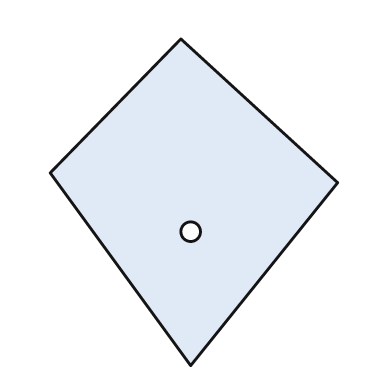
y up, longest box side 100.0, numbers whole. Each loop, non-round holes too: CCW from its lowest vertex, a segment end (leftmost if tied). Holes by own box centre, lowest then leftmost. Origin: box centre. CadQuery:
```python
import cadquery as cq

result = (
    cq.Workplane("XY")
    .moveTo(-1.0, -50.0)
    .lineTo(44.0, 6.0)
    .lineTo(-4.0, 50.0)
    .lineTo(-44.0, 9.0)
    .close()
    .moveTo(-1.0, -9.0)
    .circle(3.0)
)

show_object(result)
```